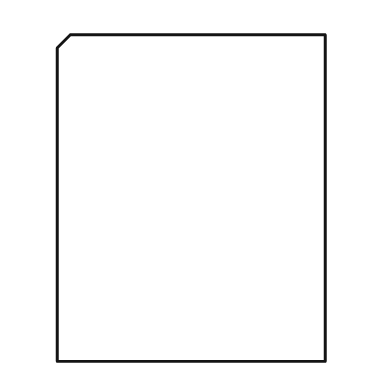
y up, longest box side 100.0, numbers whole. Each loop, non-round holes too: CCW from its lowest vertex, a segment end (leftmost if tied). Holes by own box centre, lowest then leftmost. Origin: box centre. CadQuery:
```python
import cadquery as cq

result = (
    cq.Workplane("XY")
    .moveTo(-41.0, -50.0)
    .lineTo(41.0, -50.0)
    .lineTo(41.0, 50.0)
    .lineTo(-37.0, 50.0)
    .lineTo(-41.0, 46.0)
    .close()
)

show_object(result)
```